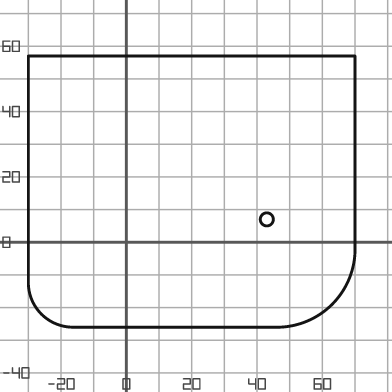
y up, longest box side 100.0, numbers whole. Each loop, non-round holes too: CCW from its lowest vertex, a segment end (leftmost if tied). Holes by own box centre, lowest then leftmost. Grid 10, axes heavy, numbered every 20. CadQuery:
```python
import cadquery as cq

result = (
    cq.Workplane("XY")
    .moveTo(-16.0, -26.0)
    .lineTo(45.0, -26.0)
    .threePointArc((63.0, -19.0), (70.0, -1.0))
    .lineTo(70.0, 57.0)
    .lineTo(-30.0, 57.0)
    .lineTo(-30.0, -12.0)
    .threePointArc((-26.0, -22.0), (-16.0, -26.0))
    .close()
    .moveTo(43.0, 7.0)
    .circle(2.0)
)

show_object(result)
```